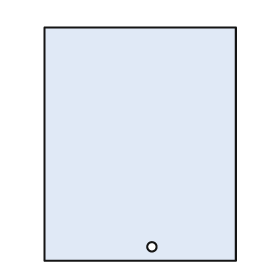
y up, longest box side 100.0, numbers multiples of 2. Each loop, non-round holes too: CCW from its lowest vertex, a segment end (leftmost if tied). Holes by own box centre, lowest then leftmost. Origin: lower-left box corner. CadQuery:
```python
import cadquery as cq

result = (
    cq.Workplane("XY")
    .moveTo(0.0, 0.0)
    .lineTo(82.0, 0.0)
    .lineTo(82.0, 100.0)
    .lineTo(0.0, 100.0)
    .close()
    .moveTo(46.0, 6.0)
    .circle(2.0)
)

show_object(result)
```